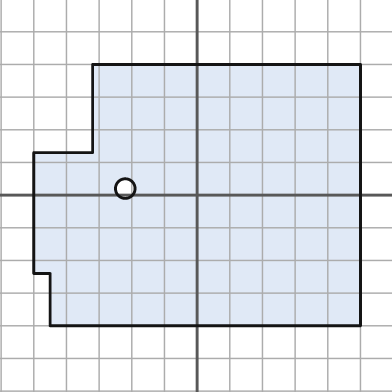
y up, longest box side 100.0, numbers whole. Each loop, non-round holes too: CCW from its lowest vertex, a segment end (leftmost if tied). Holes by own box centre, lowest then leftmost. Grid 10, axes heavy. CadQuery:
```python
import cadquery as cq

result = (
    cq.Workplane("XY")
    .moveTo(-45.0, -40.0)
    .lineTo(50.0, -40.0)
    .lineTo(50.0, 40.0)
    .lineTo(-32.0, 40.0)
    .lineTo(-32.0, 13.0)
    .lineTo(-50.0, 13.0)
    .lineTo(-50.0, -24.0)
    .lineTo(-45.0, -24.0)
    .close()
    .moveTo(-22.0, 2.0)
    .circle(3.0)
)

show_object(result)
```